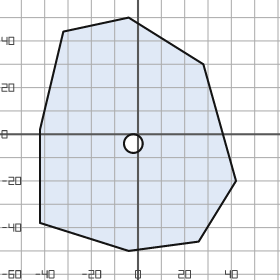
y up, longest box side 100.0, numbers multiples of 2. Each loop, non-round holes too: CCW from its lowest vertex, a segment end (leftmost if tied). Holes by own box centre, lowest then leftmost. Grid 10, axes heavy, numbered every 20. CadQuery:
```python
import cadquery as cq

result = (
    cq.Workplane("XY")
    .moveTo(-4.0, -50.0)
    .lineTo(26.0, -46.0)
    .lineTo(42.0, -20.0)
    .lineTo(28.0, 30.0)
    .lineTo(-4.0, 50.0)
    .lineTo(-32.0, 44.0)
    .lineTo(-42.0, 2.0)
    .lineTo(-42.0, -38.0)
    .close()
    .moveTo(-2.0, -4.0)
    .circle(4.0)
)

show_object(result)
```